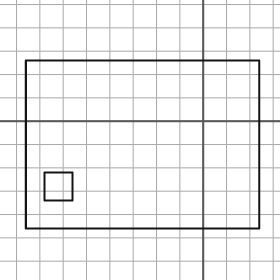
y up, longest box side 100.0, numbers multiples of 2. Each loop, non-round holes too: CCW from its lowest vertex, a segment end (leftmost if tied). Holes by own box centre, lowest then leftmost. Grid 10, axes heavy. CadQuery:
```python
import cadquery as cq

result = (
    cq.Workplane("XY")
    .moveTo(-76.0, -46.0)
    .lineTo(24.0, -46.0)
    .lineTo(24.0, 26.0)
    .lineTo(-76.0, 26.0)
    .close()
    .moveTo(-68.0, -34.0)
    .lineTo(-56.0, -34.0)
    .lineTo(-56.0, -22.0)
    .lineTo(-68.0, -22.0)
    .close()
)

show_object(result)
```